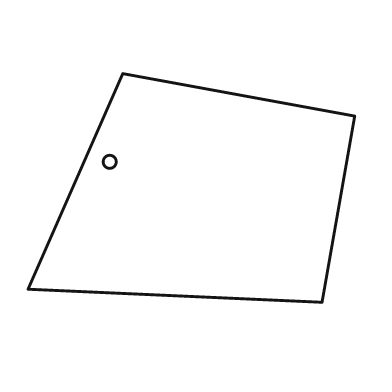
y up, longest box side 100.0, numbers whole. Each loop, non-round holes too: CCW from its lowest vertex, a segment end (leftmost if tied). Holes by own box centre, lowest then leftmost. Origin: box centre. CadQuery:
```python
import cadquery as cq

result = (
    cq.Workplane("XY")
    .moveTo(40.0, -35.0)
    .lineTo(50.0, 22.0)
    .lineTo(-21.0, 35.0)
    .lineTo(-50.0, -31.0)
    .close()
    .moveTo(-25.0, 8.0)
    .circle(2.0)
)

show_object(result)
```